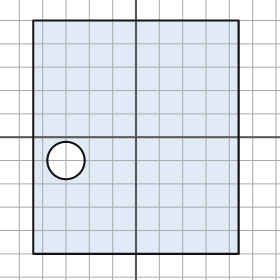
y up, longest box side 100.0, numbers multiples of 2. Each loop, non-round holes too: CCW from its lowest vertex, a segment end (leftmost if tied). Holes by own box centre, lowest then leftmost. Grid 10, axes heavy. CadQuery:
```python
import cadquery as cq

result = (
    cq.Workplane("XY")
    .moveTo(-44.0, -50.0)
    .lineTo(44.0, -50.0)
    .lineTo(44.0, 50.0)
    .lineTo(-44.0, 50.0)
    .close()
    .moveTo(-30.0, -10.0)
    .circle(8.0)
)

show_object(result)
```